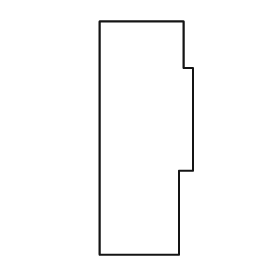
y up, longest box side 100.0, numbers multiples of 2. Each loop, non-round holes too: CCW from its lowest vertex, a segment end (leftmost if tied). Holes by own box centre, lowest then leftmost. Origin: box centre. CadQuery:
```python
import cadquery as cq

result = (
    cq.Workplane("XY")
    .moveTo(-20.0, -50.0)
    .lineTo(14.0, -50.0)
    .lineTo(14.0, -14.0)
    .lineTo(20.0, -14.0)
    .lineTo(20.0, 30.0)
    .lineTo(16.0, 30.0)
    .lineTo(16.0, 50.0)
    .lineTo(-20.0, 50.0)
    .close()
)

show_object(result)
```